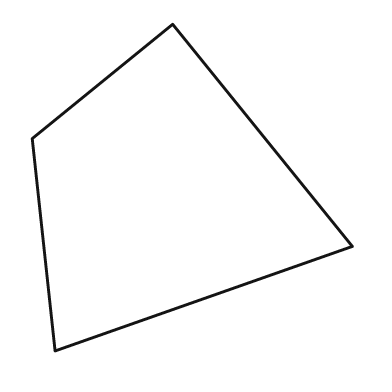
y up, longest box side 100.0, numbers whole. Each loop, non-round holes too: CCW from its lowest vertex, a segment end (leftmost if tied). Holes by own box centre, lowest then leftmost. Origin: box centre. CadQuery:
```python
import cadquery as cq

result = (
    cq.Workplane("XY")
    .moveTo(-42.0, -50.0)
    .lineTo(49.0, -18.0)
    .lineTo(-6.0, 50.0)
    .lineTo(-49.0, 15.0)
    .close()
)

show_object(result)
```